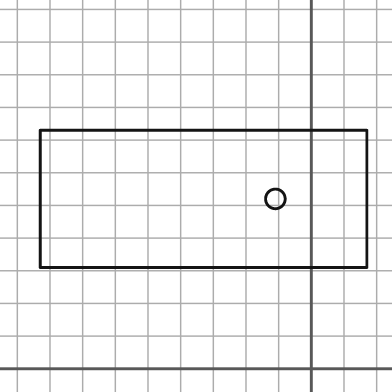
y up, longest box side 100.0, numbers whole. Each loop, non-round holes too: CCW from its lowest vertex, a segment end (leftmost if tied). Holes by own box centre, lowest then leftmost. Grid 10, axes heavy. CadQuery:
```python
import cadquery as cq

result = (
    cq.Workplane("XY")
    .moveTo(-83.0, 31.0)
    .lineTo(17.0, 31.0)
    .lineTo(17.0, 73.0)
    .lineTo(-83.0, 73.0)
    .close()
    .moveTo(-11.0, 52.0)
    .circle(3.0)
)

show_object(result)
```